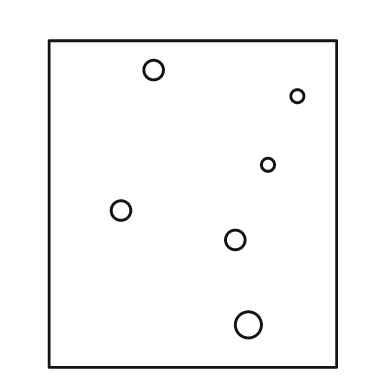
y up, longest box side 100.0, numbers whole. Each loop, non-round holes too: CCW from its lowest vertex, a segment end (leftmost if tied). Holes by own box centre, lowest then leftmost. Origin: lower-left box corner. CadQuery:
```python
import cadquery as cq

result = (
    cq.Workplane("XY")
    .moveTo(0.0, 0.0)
    .lineTo(88.0, 0.0)
    .lineTo(88.0, 100.0)
    .lineTo(0.0, 100.0)
    .close()
    .moveTo(61.0, 13.0)
    .circle(4.0)
    .moveTo(57.0, 39.0)
    .circle(3.0)
    .moveTo(22.0, 48.0)
    .circle(3.0)
    .moveTo(67.0, 62.0)
    .circle(2.0)
    .moveTo(76.0, 83.0)
    .circle(2.0)
    .moveTo(32.0, 91.0)
    .circle(3.0)
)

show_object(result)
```